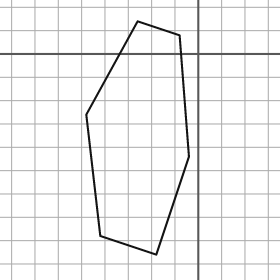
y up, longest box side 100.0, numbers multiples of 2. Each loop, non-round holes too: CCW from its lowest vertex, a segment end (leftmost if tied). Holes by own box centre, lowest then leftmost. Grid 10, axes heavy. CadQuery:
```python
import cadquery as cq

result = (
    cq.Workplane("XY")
    .moveTo(-18.0, -86.0)
    .lineTo(-4.0, -44.0)
    .lineTo(-8.0, 8.0)
    .lineTo(-26.0, 14.0)
    .lineTo(-48.0, -26.0)
    .lineTo(-42.0, -78.0)
    .close()
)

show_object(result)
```